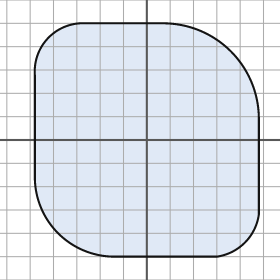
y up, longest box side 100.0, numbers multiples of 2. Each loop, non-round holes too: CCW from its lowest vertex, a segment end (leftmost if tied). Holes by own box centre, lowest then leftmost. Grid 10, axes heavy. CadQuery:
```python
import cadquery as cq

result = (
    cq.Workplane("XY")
    .moveTo(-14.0, -50.0)
    .lineTo(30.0, -50.0)
    .threePointArc((42.0, -44.0), (48.0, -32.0))
    .lineTo(48.0, 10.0)
    .threePointArc((36.0, 38.0), (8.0, 50.0))
    .lineTo(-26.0, 50.0)
    .threePointArc((-42.0, 44.0), (-48.0, 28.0))
    .lineTo(-48.0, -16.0)
    .threePointArc((-38.0, -40.0), (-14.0, -50.0))
    .close()
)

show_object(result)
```